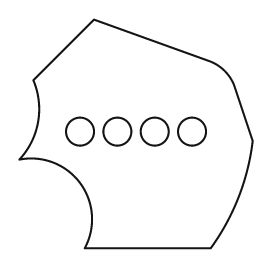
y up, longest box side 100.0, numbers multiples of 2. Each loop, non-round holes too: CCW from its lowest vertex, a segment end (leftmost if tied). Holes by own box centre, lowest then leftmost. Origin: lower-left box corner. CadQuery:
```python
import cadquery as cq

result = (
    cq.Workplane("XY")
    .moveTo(28.0, 0.0)
    .lineTo(82.0, 0.0)
    .threePointArc((94.0, 22.0), (100.0, 46.0))
    .lineTo(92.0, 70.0)
    .threePointArc((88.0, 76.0), (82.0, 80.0))
    .lineTo(32.0, 98.0)
    .lineTo(6.0, 72.0)
    .threePointArc((8.0, 54.0), (0.0, 38.0))
    .threePointArc((26.0, 28.0), (28.0, 0.0))
    .close()
    .moveTo(26.0, 50.0)
    .circle(6.0)
    .moveTo(42.0, 50.0)
    .circle(6.0)
    .moveTo(58.0, 50.0)
    .circle(6.0)
    .moveTo(74.0, 50.0)
    .circle(6.0)
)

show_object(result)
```